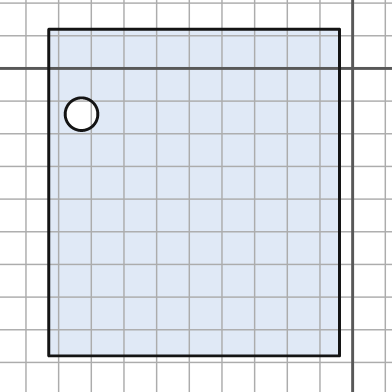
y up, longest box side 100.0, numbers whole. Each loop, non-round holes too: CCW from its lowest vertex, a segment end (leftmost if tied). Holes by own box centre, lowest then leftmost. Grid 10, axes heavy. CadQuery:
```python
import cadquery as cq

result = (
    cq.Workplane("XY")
    .moveTo(-93.0, -88.0)
    .lineTo(-4.0, -88.0)
    .lineTo(-4.0, 12.0)
    .lineTo(-93.0, 12.0)
    .close()
    .moveTo(-83.0, -14.0)
    .circle(5.0)
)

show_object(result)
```